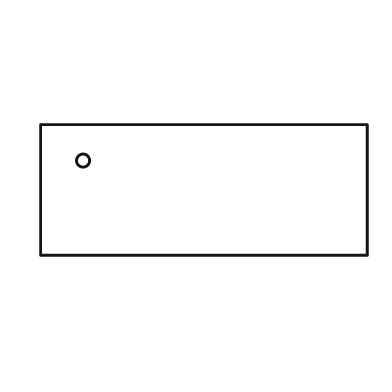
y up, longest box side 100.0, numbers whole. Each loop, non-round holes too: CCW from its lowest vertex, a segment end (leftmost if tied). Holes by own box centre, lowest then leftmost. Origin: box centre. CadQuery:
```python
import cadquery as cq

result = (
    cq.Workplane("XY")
    .moveTo(-50.0, -20.0)
    .lineTo(50.0, -20.0)
    .lineTo(50.0, 20.0)
    .lineTo(-50.0, 20.0)
    .close()
    .moveTo(-37.0, 9.0)
    .circle(2.0)
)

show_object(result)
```